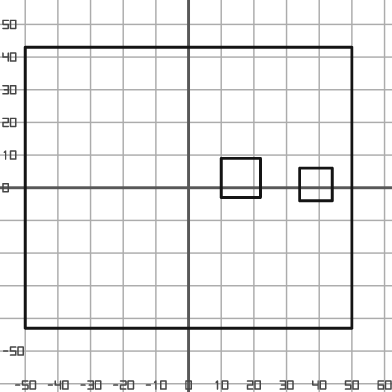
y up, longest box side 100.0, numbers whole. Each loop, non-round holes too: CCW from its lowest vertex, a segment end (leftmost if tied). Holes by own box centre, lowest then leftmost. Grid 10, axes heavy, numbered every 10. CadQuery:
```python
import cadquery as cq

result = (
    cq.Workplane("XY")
    .moveTo(-50.0, -43.0)
    .lineTo(50.0, -43.0)
    .lineTo(50.0, 43.0)
    .lineTo(-50.0, 43.0)
    .close()
    .moveTo(34.0, -4.0)
    .lineTo(44.0, -4.0)
    .lineTo(44.0, 6.0)
    .lineTo(34.0, 6.0)
    .close()
    .moveTo(10.0, -3.0)
    .lineTo(22.0, -3.0)
    .lineTo(22.0, 9.0)
    .lineTo(10.0, 9.0)
    .close()
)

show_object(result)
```